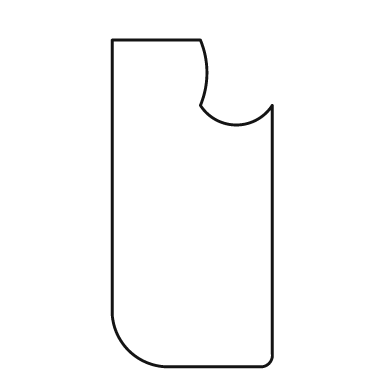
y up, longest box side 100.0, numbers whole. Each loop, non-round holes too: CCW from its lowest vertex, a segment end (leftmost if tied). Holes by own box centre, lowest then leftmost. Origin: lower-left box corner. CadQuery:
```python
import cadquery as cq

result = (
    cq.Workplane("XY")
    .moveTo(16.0, 0.0)
    .lineTo(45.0, 0.0)
    .threePointArc((48.0, 1.0), (49.0, 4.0))
    .lineTo(49.0, 80.0)
    .threePointArc((38.0, 74.0), (27.0, 80.0))
    .threePointArc((29.0, 90.0), (27.0, 100.0))
    .lineTo(0.0, 100.0)
    .lineTo(0.0, 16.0)
    .threePointArc((5.0, 5.0), (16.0, 0.0))
    .close()
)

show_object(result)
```